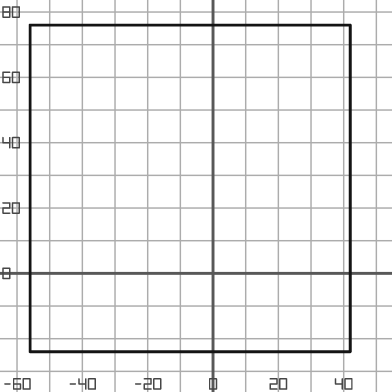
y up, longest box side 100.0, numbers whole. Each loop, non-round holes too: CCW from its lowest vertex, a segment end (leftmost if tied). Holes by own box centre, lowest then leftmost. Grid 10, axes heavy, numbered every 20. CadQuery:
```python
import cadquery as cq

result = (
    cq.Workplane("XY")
    .moveTo(-56.0, -24.0)
    .lineTo(42.0, -24.0)
    .lineTo(42.0, 76.0)
    .lineTo(-56.0, 76.0)
    .close()
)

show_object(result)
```